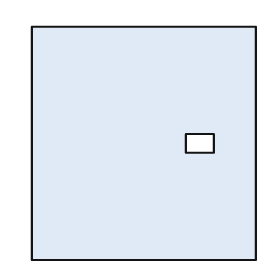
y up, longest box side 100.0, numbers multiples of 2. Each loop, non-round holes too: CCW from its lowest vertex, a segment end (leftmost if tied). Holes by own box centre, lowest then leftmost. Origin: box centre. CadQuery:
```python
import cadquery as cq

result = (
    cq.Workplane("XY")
    .moveTo(-48.0, -50.0)
    .lineTo(48.0, -50.0)
    .lineTo(48.0, 50.0)
    .lineTo(-48.0, 50.0)
    .close()
    .moveTo(18.0, -4.0)
    .lineTo(30.0, -4.0)
    .lineTo(30.0, 4.0)
    .lineTo(18.0, 4.0)
    .close()
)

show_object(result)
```